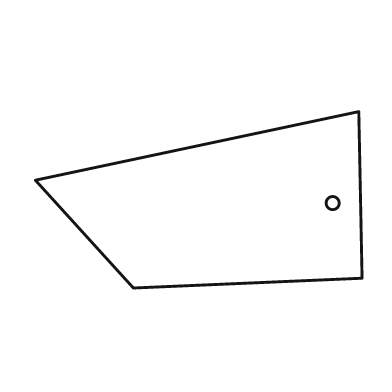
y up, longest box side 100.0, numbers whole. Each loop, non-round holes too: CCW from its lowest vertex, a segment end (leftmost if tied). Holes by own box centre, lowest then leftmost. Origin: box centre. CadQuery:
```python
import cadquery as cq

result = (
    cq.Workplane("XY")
    .moveTo(-20.0, -27.0)
    .lineTo(50.0, -24.0)
    .lineTo(49.0, 27.0)
    .lineTo(-50.0, 6.0)
    .close()
    .moveTo(41.0, -1.0)
    .circle(2.0)
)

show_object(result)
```